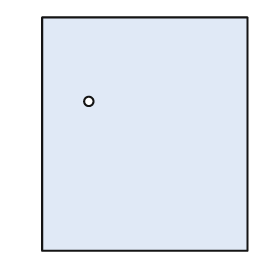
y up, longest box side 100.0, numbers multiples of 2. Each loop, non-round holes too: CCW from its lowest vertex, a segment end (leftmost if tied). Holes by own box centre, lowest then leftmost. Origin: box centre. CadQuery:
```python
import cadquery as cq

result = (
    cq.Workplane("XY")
    .moveTo(-44.0, -50.0)
    .lineTo(44.0, -50.0)
    .lineTo(44.0, 50.0)
    .lineTo(-44.0, 50.0)
    .close()
    .moveTo(-24.0, 14.0)
    .circle(2.0)
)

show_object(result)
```